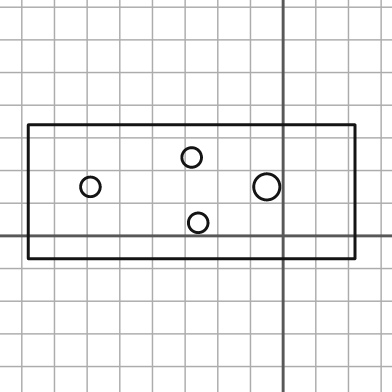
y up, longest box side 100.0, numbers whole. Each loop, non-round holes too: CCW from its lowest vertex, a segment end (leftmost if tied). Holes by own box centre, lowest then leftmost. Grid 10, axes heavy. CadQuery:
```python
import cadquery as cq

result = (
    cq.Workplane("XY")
    .moveTo(-78.0, -7.0)
    .lineTo(22.0, -7.0)
    .lineTo(22.0, 34.0)
    .lineTo(-78.0, 34.0)
    .close()
    .moveTo(-26.0, 4.0)
    .circle(3.0)
    .moveTo(-59.0, 15.0)
    .circle(3.0)
    .moveTo(-5.0, 15.0)
    .circle(4.0)
    .moveTo(-28.0, 24.0)
    .circle(3.0)
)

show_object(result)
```